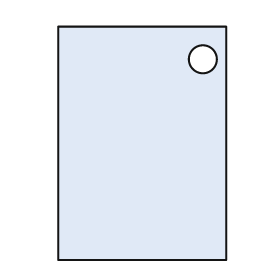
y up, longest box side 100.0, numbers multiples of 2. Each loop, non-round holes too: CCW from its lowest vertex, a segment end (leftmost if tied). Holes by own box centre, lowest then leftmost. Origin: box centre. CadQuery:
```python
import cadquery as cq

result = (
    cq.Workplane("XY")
    .moveTo(-36.0, -50.0)
    .lineTo(36.0, -50.0)
    .lineTo(36.0, 50.0)
    .lineTo(-36.0, 50.0)
    .close()
    .moveTo(26.0, 36.0)
    .circle(6.0)
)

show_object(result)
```